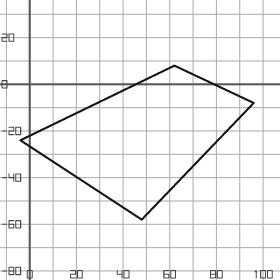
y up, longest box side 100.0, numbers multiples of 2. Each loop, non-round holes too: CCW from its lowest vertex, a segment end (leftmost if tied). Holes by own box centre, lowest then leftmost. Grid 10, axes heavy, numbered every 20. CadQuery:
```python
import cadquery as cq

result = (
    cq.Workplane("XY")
    .moveTo(48.0, -58.0)
    .lineTo(96.0, -8.0)
    .lineTo(62.0, 8.0)
    .lineTo(-4.0, -24.0)
    .close()
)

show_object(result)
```